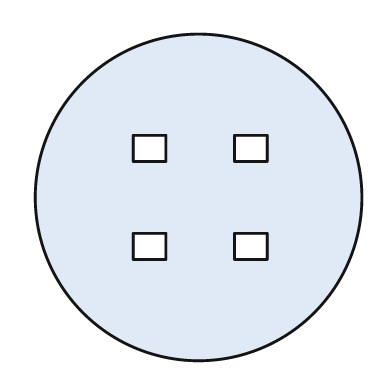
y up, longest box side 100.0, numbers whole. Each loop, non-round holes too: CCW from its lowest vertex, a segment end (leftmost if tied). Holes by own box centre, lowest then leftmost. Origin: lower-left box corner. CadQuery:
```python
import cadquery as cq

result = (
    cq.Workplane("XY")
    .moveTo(50.0, 50.0)
    .circle(50.0)
    .moveTo(30.0, 31.0)
    .lineTo(40.0, 31.0)
    .lineTo(40.0, 39.0)
    .lineTo(30.0, 39.0)
    .close()
    .moveTo(61.0, 31.0)
    .lineTo(71.0, 31.0)
    .lineTo(71.0, 39.0)
    .lineTo(61.0, 39.0)
    .close()
    .moveTo(30.0, 61.0)
    .lineTo(40.0, 61.0)
    .lineTo(40.0, 69.0)
    .lineTo(30.0, 69.0)
    .close()
    .moveTo(61.0, 61.0)
    .lineTo(71.0, 61.0)
    .lineTo(71.0, 69.0)
    .lineTo(61.0, 69.0)
    .close()
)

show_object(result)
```